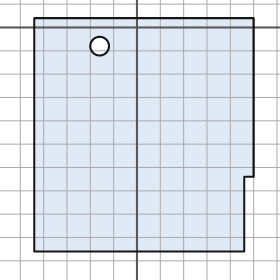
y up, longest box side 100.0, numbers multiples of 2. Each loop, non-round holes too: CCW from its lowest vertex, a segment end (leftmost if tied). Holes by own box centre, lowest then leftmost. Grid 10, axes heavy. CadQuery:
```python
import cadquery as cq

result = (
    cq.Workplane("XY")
    .moveTo(-44.0, -96.0)
    .lineTo(46.0, -96.0)
    .lineTo(46.0, -64.0)
    .lineTo(50.0, -64.0)
    .lineTo(50.0, 4.0)
    .lineTo(-44.0, 4.0)
    .close()
    .moveTo(-16.0, -8.0)
    .circle(4.0)
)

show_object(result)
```